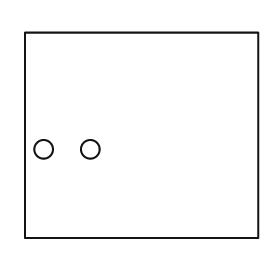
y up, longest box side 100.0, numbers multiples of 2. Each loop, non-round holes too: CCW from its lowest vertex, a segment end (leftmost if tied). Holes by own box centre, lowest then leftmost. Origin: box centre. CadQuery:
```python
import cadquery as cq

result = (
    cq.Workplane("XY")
    .moveTo(-50.0, -44.0)
    .lineTo(50.0, -44.0)
    .lineTo(50.0, 44.0)
    .lineTo(-50.0, 44.0)
    .close()
    .moveTo(-42.0, -6.0)
    .circle(4.0)
    .moveTo(-22.0, -6.0)
    .circle(4.0)
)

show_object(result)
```